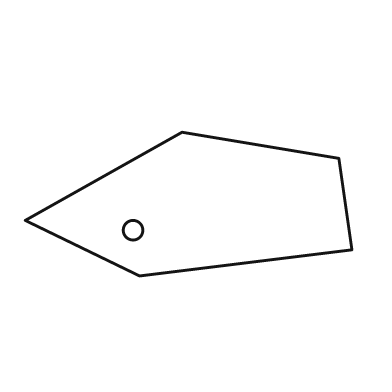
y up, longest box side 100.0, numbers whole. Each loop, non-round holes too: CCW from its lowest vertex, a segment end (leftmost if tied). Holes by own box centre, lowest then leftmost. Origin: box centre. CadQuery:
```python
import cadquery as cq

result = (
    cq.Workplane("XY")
    .moveTo(-15.0, -22.0)
    .lineTo(50.0, -14.0)
    .lineTo(46.0, 14.0)
    .lineTo(-2.0, 22.0)
    .lineTo(-50.0, -5.0)
    .close()
    .moveTo(-17.0, -8.0)
    .circle(3.0)
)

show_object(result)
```